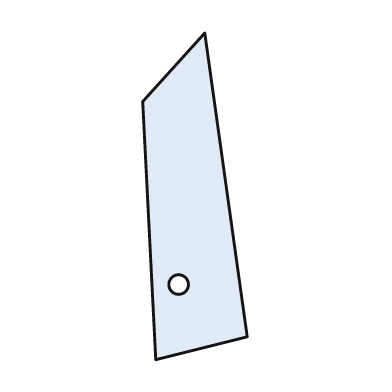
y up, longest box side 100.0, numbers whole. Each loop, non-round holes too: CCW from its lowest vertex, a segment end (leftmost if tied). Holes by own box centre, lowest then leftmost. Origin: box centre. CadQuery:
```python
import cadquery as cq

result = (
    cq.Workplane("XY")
    .moveTo(-12.0, -50.0)
    .lineTo(16.0, -43.0)
    .lineTo(3.0, 50.0)
    .lineTo(-16.0, 29.0)
    .close()
    .moveTo(-5.0, -27.0)
    .circle(3.0)
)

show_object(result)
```